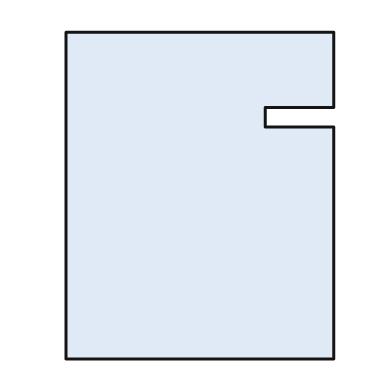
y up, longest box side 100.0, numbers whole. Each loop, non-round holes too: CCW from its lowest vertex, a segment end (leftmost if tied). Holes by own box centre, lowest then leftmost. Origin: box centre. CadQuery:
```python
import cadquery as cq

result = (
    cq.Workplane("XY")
    .moveTo(-41.0, -50.0)
    .lineTo(41.0, -50.0)
    .lineTo(41.0, 21.0)
    .lineTo(20.0, 21.0)
    .lineTo(20.0, 27.0)
    .lineTo(41.0, 27.0)
    .lineTo(41.0, 50.0)
    .lineTo(-41.0, 50.0)
    .close()
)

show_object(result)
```